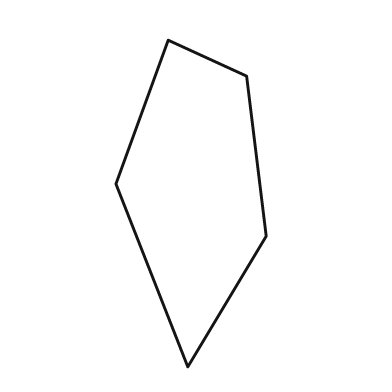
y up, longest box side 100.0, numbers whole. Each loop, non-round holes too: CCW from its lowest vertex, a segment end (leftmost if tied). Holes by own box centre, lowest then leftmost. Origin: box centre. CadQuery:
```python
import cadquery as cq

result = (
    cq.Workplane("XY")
    .moveTo(-1.0, -50.0)
    .lineTo(23.0, -10.0)
    .lineTo(17.0, 39.0)
    .lineTo(-7.0, 50.0)
    .lineTo(-23.0, 6.0)
    .close()
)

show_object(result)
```